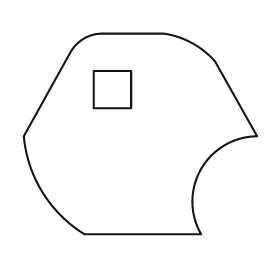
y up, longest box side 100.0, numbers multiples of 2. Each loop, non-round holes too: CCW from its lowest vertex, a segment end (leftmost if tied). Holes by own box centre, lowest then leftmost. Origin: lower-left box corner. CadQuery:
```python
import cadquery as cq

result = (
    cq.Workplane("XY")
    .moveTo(26.0, 0.0)
    .lineTo(76.0, 0.0)
    .threePointArc((76.0, 28.0), (100.0, 42.0))
    .lineTo(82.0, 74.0)
    .threePointArc((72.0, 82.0), (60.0, 86.0))
    .lineTo(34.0, 86.0)
    .threePointArc((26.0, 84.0), (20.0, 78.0))
    .lineTo(0.0, 42.0)
    .threePointArc((8.0, 18.0), (26.0, 0.0))
    .close()
    .moveTo(30.0, 54.0)
    .lineTo(46.0, 54.0)
    .lineTo(46.0, 70.0)
    .lineTo(30.0, 70.0)
    .close()
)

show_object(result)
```